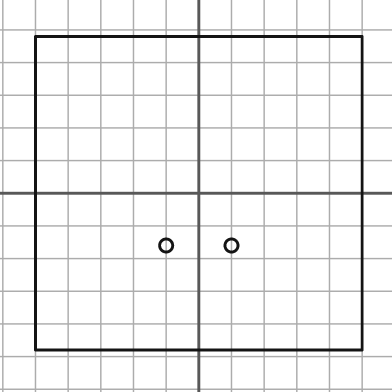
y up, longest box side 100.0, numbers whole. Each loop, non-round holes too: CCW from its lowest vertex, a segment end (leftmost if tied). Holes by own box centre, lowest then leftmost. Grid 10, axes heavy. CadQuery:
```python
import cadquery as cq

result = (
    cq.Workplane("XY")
    .moveTo(-50.0, -48.0)
    .lineTo(50.0, -48.0)
    .lineTo(50.0, 48.0)
    .lineTo(-50.0, 48.0)
    .close()
    .moveTo(-10.0, -16.0)
    .circle(2.0)
    .moveTo(10.0, -16.0)
    .circle(2.0)
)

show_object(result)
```